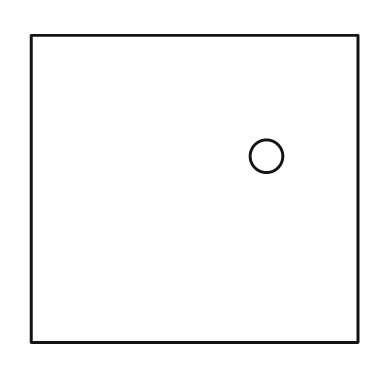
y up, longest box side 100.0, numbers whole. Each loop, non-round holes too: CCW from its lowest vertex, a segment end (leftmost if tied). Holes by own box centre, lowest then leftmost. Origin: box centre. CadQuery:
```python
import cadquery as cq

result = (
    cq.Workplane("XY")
    .moveTo(-50.0, -47.0)
    .lineTo(50.0, -47.0)
    .lineTo(50.0, 47.0)
    .lineTo(-50.0, 47.0)
    .close()
    .moveTo(22.0, 10.0)
    .circle(5.0)
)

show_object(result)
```